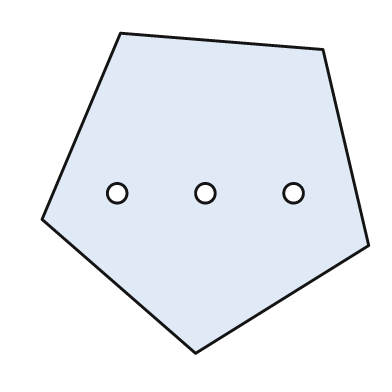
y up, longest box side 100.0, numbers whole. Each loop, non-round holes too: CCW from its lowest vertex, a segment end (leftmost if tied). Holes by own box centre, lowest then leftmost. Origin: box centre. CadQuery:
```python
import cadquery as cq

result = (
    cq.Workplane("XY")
    .moveTo(-3.0, -49.0)
    .lineTo(50.0, -16.0)
    .lineTo(36.0, 44.0)
    .lineTo(-26.0, 49.0)
    .lineTo(-50.0, -8.0)
    .close()
    .moveTo(-27.0, 0.0)
    .circle(3.0)
    .moveTo(0.0, 0.0)
    .circle(3.0)
    .moveTo(27.0, 0.0)
    .circle(3.0)
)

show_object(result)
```